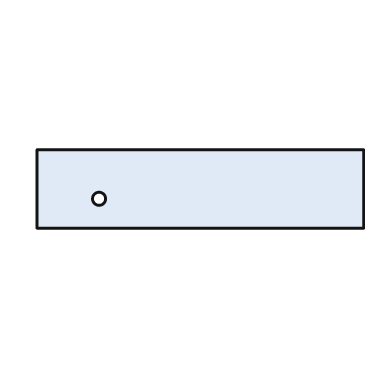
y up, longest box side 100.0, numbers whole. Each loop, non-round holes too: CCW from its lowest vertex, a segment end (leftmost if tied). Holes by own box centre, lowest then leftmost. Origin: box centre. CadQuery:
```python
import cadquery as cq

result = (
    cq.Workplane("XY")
    .moveTo(-50.0, -12.0)
    .lineTo(50.0, -12.0)
    .lineTo(50.0, 12.0)
    .lineTo(-50.0, 12.0)
    .close()
    .moveTo(-31.0, -3.0)
    .circle(2.0)
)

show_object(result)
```